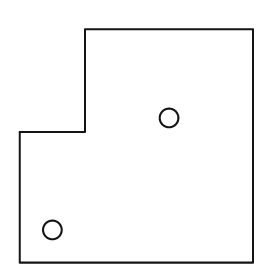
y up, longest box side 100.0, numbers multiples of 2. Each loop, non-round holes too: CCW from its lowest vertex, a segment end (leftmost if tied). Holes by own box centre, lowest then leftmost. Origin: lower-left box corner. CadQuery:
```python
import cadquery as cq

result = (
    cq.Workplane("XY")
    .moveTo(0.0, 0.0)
    .lineTo(100.0, 0.0)
    .lineTo(100.0, 100.0)
    .lineTo(28.0, 100.0)
    .lineTo(28.0, 56.0)
    .lineTo(0.0, 56.0)
    .close()
    .moveTo(14.0, 14.0)
    .circle(4.0)
    .moveTo(64.0, 62.0)
    .circle(4.0)
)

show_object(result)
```